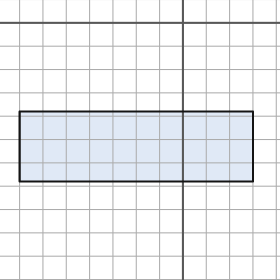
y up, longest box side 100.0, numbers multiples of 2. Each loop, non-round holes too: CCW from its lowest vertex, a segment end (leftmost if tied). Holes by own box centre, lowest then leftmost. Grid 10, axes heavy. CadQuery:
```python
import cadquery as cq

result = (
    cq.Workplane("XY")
    .moveTo(-70.0, -68.0)
    .lineTo(30.0, -68.0)
    .lineTo(30.0, -38.0)
    .lineTo(-70.0, -38.0)
    .close()
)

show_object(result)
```